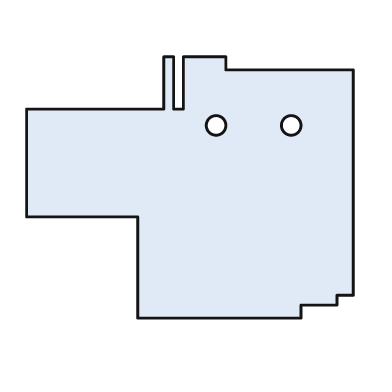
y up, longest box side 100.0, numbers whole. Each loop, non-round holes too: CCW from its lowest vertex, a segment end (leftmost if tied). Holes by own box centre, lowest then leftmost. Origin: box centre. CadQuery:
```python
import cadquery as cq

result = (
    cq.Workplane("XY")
    .moveTo(-16.0, -40.0)
    .lineTo(34.0, -40.0)
    .lineTo(34.0, -36.0)
    .lineTo(45.0, -36.0)
    .lineTo(45.0, -33.0)
    .lineTo(50.0, -33.0)
    .lineTo(50.0, 36.0)
    .lineTo(11.0, 36.0)
    .lineTo(11.0, 40.0)
    .lineTo(-2.0, 40.0)
    .lineTo(-2.0, 24.0)
    .lineTo(-5.0, 24.0)
    .lineTo(-5.0, 40.0)
    .lineTo(-8.0, 40.0)
    .lineTo(-8.0, 24.0)
    .lineTo(-50.0, 24.0)
    .lineTo(-50.0, -9.0)
    .lineTo(-16.0, -9.0)
    .close()
    .moveTo(8.0, 19.0)
    .circle(3.0)
    .moveTo(31.0, 19.0)
    .circle(3.0)
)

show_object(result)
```